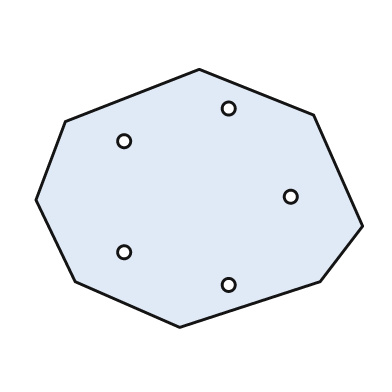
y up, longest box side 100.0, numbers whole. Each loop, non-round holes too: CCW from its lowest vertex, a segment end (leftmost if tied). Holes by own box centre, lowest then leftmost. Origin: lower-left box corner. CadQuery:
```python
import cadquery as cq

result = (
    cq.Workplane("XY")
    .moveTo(44.0, 0.0)
    .lineTo(87.0, 14.0)
    .lineTo(100.0, 31.0)
    .lineTo(85.0, 65.0)
    .lineTo(50.0, 79.0)
    .lineTo(9.0, 63.0)
    .lineTo(0.0, 39.0)
    .lineTo(12.0, 14.0)
    .close()
    .moveTo(59.0, 13.0)
    .circle(2.0)
    .moveTo(27.0, 23.0)
    .circle(2.0)
    .moveTo(78.0, 40.0)
    .circle(2.0)
    .moveTo(27.0, 57.0)
    .circle(2.0)
    .moveTo(59.0, 67.0)
    .circle(2.0)
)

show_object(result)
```